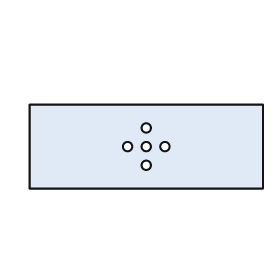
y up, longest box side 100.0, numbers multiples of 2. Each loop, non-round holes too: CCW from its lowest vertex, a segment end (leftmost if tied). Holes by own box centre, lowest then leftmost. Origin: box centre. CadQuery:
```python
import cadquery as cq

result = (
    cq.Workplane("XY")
    .moveTo(-50.0, -18.0)
    .lineTo(50.0, -18.0)
    .lineTo(50.0, 18.0)
    .lineTo(-50.0, 18.0)
    .close()
    .moveTo(0.0, -8.0)
    .circle(2.0)
    .moveTo(-8.0, 0.0)
    .circle(2.0)
    .moveTo(0.0, 0.0)
    .circle(2.0)
    .moveTo(8.0, 0.0)
    .circle(2.0)
    .moveTo(0.0, 8.0)
    .circle(2.0)
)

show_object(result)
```